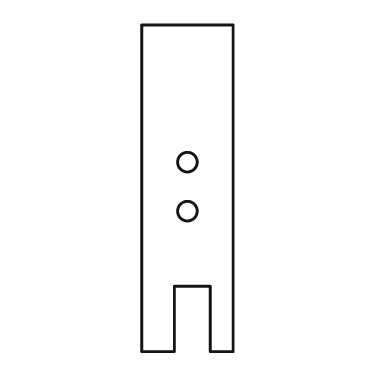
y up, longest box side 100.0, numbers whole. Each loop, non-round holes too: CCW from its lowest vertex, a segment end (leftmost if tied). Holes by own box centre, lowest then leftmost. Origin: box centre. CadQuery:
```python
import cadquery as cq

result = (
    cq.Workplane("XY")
    .moveTo(-14.0, -50.0)
    .lineTo(-4.0, -50.0)
    .lineTo(-4.0, -30.0)
    .lineTo(7.0, -30.0)
    .lineTo(7.0, -50.0)
    .lineTo(14.0, -50.0)
    .lineTo(14.0, 50.0)
    .lineTo(-14.0, 50.0)
    .close()
    .moveTo(0.0, -7.0)
    .circle(3.0)
    .moveTo(0.0, 8.0)
    .circle(3.0)
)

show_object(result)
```